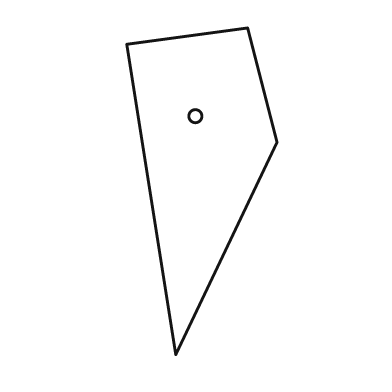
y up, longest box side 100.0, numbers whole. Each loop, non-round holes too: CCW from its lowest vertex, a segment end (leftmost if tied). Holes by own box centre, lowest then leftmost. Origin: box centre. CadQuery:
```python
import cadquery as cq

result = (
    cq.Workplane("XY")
    .moveTo(-8.0, -50.0)
    .lineTo(23.0, 15.0)
    .lineTo(14.0, 50.0)
    .lineTo(-23.0, 45.0)
    .close()
    .moveTo(-2.0, 23.0)
    .circle(2.0)
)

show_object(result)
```